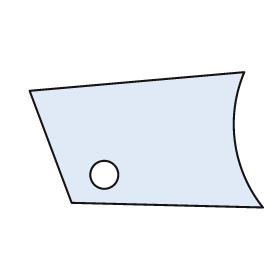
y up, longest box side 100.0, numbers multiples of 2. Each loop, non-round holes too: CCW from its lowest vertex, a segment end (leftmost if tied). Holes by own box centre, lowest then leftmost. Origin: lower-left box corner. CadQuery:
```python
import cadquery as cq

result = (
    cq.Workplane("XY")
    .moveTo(100.0, 0.0)
    .threePointArc((88.0, 28.0), (92.0, 58.0))
    .lineTo(0.0, 50.0)
    .lineTo(18.0, 2.0)
    .close()
    .moveTo(32.0, 14.0)
    .circle(6.0)
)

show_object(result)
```